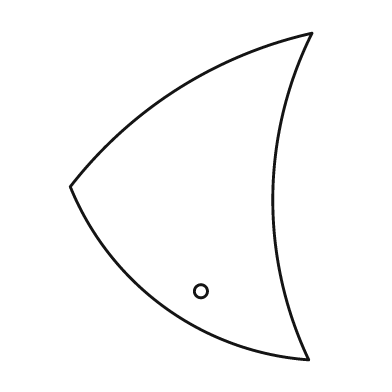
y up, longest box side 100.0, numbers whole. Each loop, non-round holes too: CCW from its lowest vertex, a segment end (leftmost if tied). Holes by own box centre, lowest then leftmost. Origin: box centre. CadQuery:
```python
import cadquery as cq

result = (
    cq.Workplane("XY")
    .moveTo(36.0, -50.0)
    .threePointArc((25.0, 0.0), (37.0, 50.0))
    .threePointArc((-4.0, 33.0), (-37.0, 3.0))
    .threePointArc((-8.0, -34.0), (36.0, -50.0))
    .close()
    .moveTo(3.0, -29.0)
    .circle(2.0)
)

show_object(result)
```